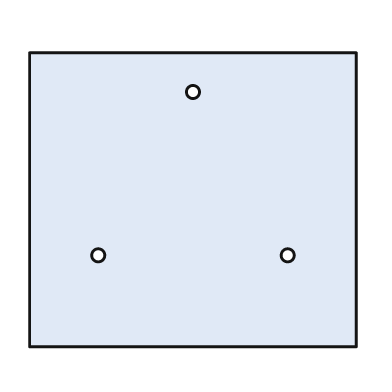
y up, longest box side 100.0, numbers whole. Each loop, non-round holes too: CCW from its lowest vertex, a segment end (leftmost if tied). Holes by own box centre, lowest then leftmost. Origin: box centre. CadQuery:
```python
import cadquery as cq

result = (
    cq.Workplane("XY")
    .moveTo(-50.0, -45.0)
    .lineTo(50.0, -45.0)
    .lineTo(50.0, 45.0)
    .lineTo(-50.0, 45.0)
    .close()
    .moveTo(-29.0, -17.0)
    .circle(2.0)
    .moveTo(29.0, -17.0)
    .circle(2.0)
    .moveTo(0.0, 33.0)
    .circle(2.0)
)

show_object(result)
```